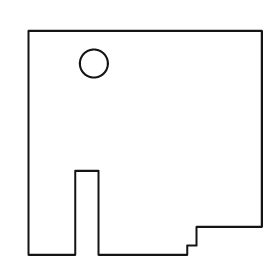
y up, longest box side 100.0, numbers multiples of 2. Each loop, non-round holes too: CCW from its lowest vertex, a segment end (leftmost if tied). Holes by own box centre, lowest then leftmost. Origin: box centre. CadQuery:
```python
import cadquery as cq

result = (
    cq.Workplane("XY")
    .moveTo(-50.0, -48.0)
    .lineTo(-30.0, -48.0)
    .lineTo(-30.0, -12.0)
    .lineTo(-20.0, -12.0)
    .lineTo(-20.0, -48.0)
    .lineTo(18.0, -48.0)
    .lineTo(18.0, -44.0)
    .lineTo(22.0, -44.0)
    .lineTo(22.0, -36.0)
    .lineTo(50.0, -36.0)
    .lineTo(50.0, 48.0)
    .lineTo(-50.0, 48.0)
    .close()
    .moveTo(-22.0, 34.0)
    .circle(6.0)
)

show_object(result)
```